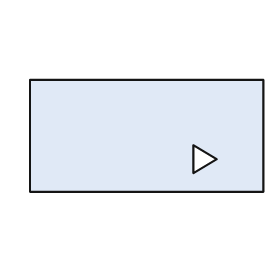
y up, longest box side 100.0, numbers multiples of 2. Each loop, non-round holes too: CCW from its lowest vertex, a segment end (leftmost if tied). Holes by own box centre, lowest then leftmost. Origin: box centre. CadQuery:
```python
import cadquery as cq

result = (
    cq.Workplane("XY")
    .moveTo(-50.0, -24.0)
    .lineTo(50.0, -24.0)
    .lineTo(50.0, 24.0)
    .lineTo(-50.0, 24.0)
    .close()
    .moveTo(20.0, -16.0)
    .lineTo(30.0, -10.0)
    .lineTo(20.0, -4.0)
    .close()
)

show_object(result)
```